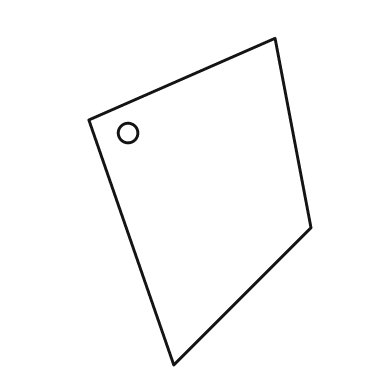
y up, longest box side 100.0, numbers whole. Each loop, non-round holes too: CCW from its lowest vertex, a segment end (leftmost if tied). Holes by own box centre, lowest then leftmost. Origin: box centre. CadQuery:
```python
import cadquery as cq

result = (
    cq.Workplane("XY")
    .moveTo(-8.0, -50.0)
    .lineTo(34.0, -8.0)
    .lineTo(23.0, 50.0)
    .lineTo(-34.0, 25.0)
    .close()
    .moveTo(-22.0, 21.0)
    .circle(3.0)
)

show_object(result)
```